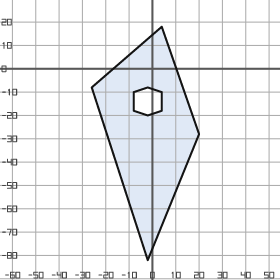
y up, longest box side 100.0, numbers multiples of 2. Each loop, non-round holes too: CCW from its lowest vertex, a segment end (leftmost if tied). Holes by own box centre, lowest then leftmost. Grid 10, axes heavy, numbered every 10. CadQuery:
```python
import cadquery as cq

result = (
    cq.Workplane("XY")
    .moveTo(-2.0, -82.0)
    .lineTo(20.0, -28.0)
    .lineTo(4.0, 18.0)
    .lineTo(-26.0, -8.0)
    .close()
    .moveTo(-2.0, -20.0)
    .lineTo(4.0, -18.0)
    .lineTo(4.0, -10.0)
    .lineTo(-2.0, -8.0)
    .lineTo(-8.0, -10.0)
    .lineTo(-8.0, -18.0)
    .close()
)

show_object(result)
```